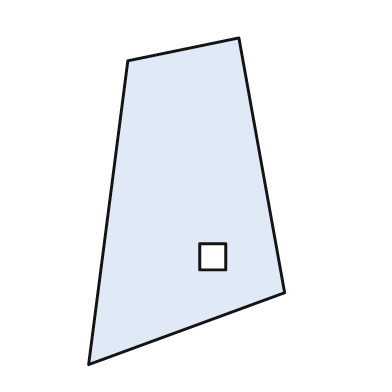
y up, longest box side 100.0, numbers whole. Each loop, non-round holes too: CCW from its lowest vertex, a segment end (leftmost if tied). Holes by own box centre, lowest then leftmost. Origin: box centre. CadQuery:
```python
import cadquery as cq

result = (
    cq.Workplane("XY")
    .moveTo(-30.0, -50.0)
    .lineTo(30.0, -28.0)
    .lineTo(16.0, 50.0)
    .lineTo(-18.0, 43.0)
    .close()
    .moveTo(4.0, -21.0)
    .lineTo(12.0, -21.0)
    .lineTo(12.0, -13.0)
    .lineTo(4.0, -13.0)
    .close()
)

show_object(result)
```